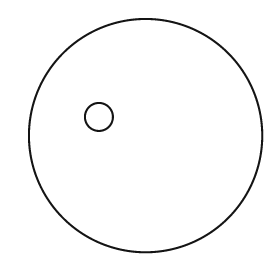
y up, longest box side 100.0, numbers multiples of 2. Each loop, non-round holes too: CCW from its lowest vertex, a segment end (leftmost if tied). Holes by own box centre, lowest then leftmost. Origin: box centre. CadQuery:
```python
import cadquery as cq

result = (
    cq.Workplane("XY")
    .moveTo(0.0, 0.0)
    .circle(50.0)
    .moveTo(-20.0, 8.0)
    .circle(6.0)
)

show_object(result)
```